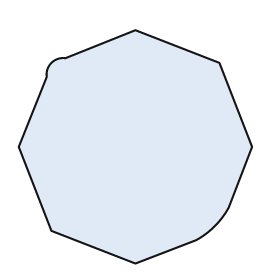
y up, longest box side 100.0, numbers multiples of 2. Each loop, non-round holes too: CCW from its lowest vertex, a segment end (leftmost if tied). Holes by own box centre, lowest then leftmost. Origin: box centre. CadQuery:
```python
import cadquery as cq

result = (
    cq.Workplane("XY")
    .moveTo(0.0, -50.0)
    .lineTo(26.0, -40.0)
    .threePointArc((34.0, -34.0), (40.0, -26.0))
    .lineTo(50.0, 0.0)
    .lineTo(36.0, 36.0)
    .lineTo(0.0, 50.0)
    .lineTo(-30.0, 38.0)
    .threePointArc((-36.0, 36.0), (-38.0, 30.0))
    .lineTo(-50.0, 0.0)
    .lineTo(-36.0, -36.0)
    .close()
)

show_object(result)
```